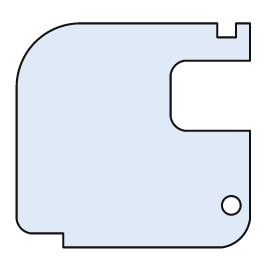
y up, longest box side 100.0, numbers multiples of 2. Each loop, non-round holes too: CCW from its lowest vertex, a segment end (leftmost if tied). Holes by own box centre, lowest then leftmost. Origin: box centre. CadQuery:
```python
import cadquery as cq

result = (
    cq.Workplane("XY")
    .moveTo(-30.0, -48.0)
    .lineTo(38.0, -48.0)
    .threePointArc((46.0, -44.0), (50.0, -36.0))
    .lineTo(50.0, 2.0)
    .lineTo(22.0, 2.0)
    .threePointArc((18.0, 4.0), (16.0, 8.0))
    .lineTo(16.0, 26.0)
    .threePointArc((18.0, 30.0), (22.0, 32.0))
    .lineTo(50.0, 32.0)
    .lineTo(50.0, 48.0)
    .lineTo(44.0, 48.0)
    .lineTo(44.0, 42.0)
    .lineTo(36.0, 42.0)
    .lineTo(36.0, 48.0)
    .lineTo(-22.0, 48.0)
    .threePointArc((-42.0, 40.0), (-50.0, 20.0))
    .lineTo(-50.0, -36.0)
    .threePointArc((-48.0, -40.0), (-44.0, -42.0))
    .lineTo(-30.0, -42.0)
    .close()
    .moveTo(42.0, -30.0)
    .circle(4.0)
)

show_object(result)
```